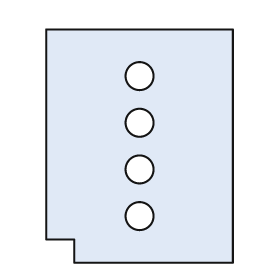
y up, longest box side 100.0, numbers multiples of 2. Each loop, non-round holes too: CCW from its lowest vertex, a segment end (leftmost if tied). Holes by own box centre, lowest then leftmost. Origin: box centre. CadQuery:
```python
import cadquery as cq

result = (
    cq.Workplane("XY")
    .moveTo(-28.0, -50.0)
    .lineTo(40.0, -50.0)
    .lineTo(40.0, 50.0)
    .lineTo(-40.0, 50.0)
    .lineTo(-40.0, -40.0)
    .lineTo(-28.0, -40.0)
    .close()
    .moveTo(0.0, -30.0)
    .circle(6.0)
    .moveTo(0.0, -10.0)
    .circle(6.0)
    .moveTo(0.0, 10.0)
    .circle(6.0)
    .moveTo(0.0, 30.0)
    .circle(6.0)
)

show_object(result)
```